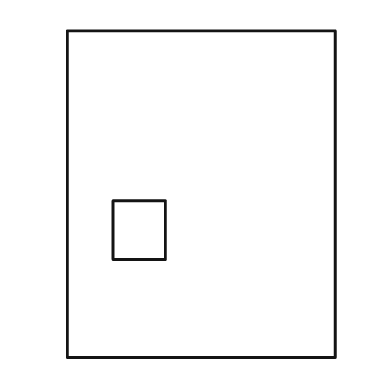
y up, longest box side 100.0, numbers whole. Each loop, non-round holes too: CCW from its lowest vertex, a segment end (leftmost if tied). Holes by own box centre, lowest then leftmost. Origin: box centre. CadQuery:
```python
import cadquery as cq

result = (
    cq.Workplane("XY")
    .moveTo(-41.0, -50.0)
    .lineTo(41.0, -50.0)
    .lineTo(41.0, 50.0)
    .lineTo(-41.0, 50.0)
    .close()
    .moveTo(-27.0, -20.0)
    .lineTo(-11.0, -20.0)
    .lineTo(-11.0, -2.0)
    .lineTo(-27.0, -2.0)
    .close()
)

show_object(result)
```